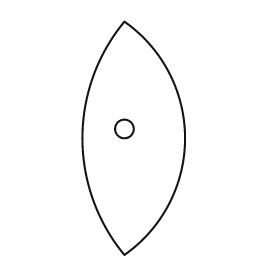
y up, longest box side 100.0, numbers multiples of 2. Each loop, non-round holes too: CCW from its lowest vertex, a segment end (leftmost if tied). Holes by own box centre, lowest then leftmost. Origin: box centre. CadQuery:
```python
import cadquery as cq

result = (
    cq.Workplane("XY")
    .moveTo(-4.0, -50.0)
    .threePointArc((22.0, 0.0), (-4.0, 50.0))
    .threePointArc((-22.0, 0.0), (-4.0, -50.0))
    .close()
    .moveTo(-4.0, 4.0)
    .circle(4.0)
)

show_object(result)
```